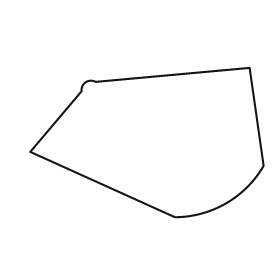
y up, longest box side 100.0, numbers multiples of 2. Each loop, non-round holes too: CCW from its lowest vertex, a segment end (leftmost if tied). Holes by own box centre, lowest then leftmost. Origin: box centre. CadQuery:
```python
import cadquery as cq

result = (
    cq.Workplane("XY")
    .moveTo(12.0, -32.0)
    .threePointArc((34.0, -26.0), (50.0, -10.0))
    .lineTo(44.0, 32.0)
    .lineTo(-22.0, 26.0)
    .threePointArc((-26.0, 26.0), (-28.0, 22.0))
    .lineTo(-50.0, -4.0)
    .close()
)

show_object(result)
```